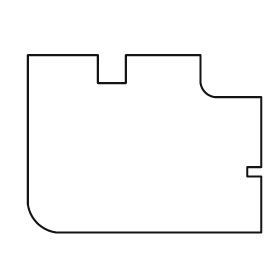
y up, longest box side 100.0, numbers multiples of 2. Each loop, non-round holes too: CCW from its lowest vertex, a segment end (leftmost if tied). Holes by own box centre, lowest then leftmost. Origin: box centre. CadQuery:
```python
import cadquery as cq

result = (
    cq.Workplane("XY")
    .moveTo(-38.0, -38.0)
    .lineTo(50.0, -38.0)
    .lineTo(50.0, -14.0)
    .lineTo(44.0, -14.0)
    .lineTo(44.0, -10.0)
    .lineTo(50.0, -10.0)
    .lineTo(50.0, 20.0)
    .lineTo(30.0, 20.0)
    .threePointArc((26.0, 22.0), (24.0, 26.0))
    .lineTo(24.0, 38.0)
    .lineTo(-8.0, 38.0)
    .lineTo(-8.0, 26.0)
    .lineTo(-20.0, 26.0)
    .lineTo(-20.0, 38.0)
    .lineTo(-50.0, 38.0)
    .lineTo(-50.0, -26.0)
    .threePointArc((-46.0, -34.0), (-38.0, -38.0))
    .close()
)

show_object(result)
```